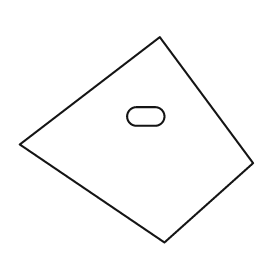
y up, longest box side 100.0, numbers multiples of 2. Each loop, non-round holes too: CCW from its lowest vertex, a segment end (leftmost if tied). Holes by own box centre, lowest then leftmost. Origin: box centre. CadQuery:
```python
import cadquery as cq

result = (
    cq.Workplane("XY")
    .moveTo(12.0, -44.0)
    .lineTo(50.0, -10.0)
    .lineTo(10.0, 44.0)
    .lineTo(-50.0, -2.0)
    .close()
    .moveTo(0.0, 6.0)
    .lineTo(8.0, 6.0)
    .threePointArc((12.0, 10.0), (8.0, 14.0))
    .lineTo(0.0, 14.0)
    .threePointArc((-4.0, 10.0), (0.0, 6.0))
    .close()
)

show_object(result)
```